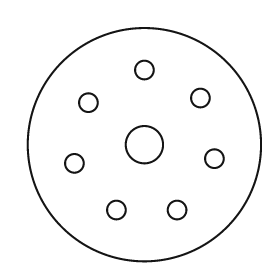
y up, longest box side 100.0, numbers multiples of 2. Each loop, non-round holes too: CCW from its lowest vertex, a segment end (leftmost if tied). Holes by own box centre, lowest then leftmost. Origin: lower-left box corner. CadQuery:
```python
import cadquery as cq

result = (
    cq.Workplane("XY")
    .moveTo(50.0, 50.0)
    .circle(50.0)
    .moveTo(38.0, 22.0)
    .circle(4.0)
    .moveTo(64.0, 22.0)
    .circle(4.0)
    .moveTo(20.0, 42.0)
    .circle(4.0)
    .moveTo(80.0, 44.0)
    .circle(4.0)
    .moveTo(50.0, 50.0)
    .circle(8.0)
    .moveTo(26.0, 68.0)
    .circle(4.0)
    .moveTo(74.0, 70.0)
    .circle(4.0)
    .moveTo(50.0, 82.0)
    .circle(4.0)
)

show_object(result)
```